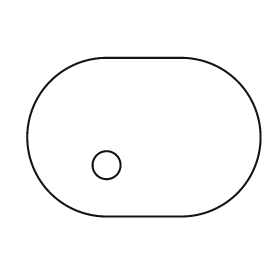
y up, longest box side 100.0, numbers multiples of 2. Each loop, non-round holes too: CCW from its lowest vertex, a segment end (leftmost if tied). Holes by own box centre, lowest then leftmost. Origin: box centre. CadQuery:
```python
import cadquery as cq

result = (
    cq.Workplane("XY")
    .moveTo(-16.0, -34.0)
    .lineTo(16.0, -34.0)
    .threePointArc((50.0, 0.0), (16.0, 34.0))
    .lineTo(-16.0, 34.0)
    .threePointArc((-50.0, 0.0), (-16.0, -34.0))
    .close()
    .moveTo(-16.0, -12.0)
    .circle(6.0)
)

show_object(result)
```